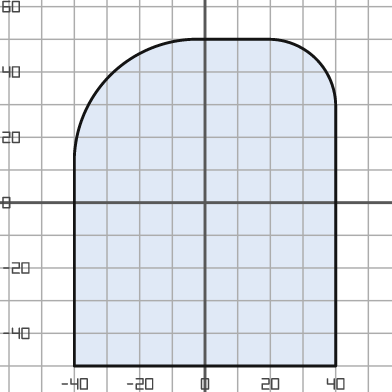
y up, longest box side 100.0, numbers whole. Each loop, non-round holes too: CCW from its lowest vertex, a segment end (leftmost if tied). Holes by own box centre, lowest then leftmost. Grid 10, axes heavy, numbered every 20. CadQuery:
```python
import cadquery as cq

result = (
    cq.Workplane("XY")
    .moveTo(-40.0, -50.0)
    .lineTo(40.0, -50.0)
    .lineTo(40.0, 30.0)
    .threePointArc((34.0, 44.0), (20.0, 50.0))
    .lineTo(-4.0, 50.0)
    .threePointArc((-29.0, 39.0), (-40.0, 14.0))
    .close()
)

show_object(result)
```